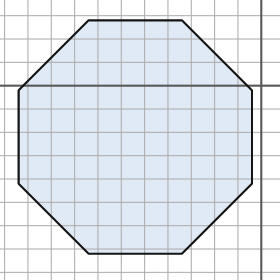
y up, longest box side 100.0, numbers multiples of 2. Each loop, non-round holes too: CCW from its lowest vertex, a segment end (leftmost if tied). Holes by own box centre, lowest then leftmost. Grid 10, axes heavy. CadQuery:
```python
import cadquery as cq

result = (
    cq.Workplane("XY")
    .moveTo(-74.0, -72.0)
    .lineTo(-34.0, -72.0)
    .lineTo(-4.0, -42.0)
    .lineTo(-4.0, -2.0)
    .lineTo(-34.0, 28.0)
    .lineTo(-74.0, 28.0)
    .lineTo(-104.0, -2.0)
    .lineTo(-104.0, -42.0)
    .close()
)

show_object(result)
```